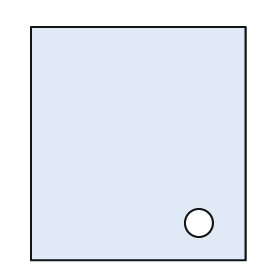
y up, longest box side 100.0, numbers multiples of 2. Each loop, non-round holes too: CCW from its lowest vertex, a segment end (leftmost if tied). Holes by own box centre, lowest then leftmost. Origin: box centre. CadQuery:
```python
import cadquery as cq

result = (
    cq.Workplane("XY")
    .moveTo(-46.0, -50.0)
    .lineTo(46.0, -50.0)
    .lineTo(46.0, 50.0)
    .lineTo(-46.0, 50.0)
    .close()
    .moveTo(26.0, -34.0)
    .circle(6.0)
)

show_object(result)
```